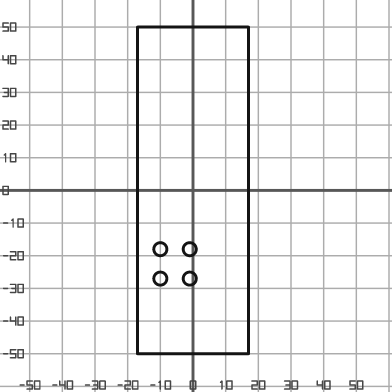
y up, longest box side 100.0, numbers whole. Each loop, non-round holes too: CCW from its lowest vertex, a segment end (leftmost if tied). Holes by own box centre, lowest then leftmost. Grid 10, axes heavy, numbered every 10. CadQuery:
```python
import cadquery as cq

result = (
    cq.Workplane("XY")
    .moveTo(-17.0, -50.0)
    .lineTo(17.0, -50.0)
    .lineTo(17.0, 50.0)
    .lineTo(-17.0, 50.0)
    .close()
    .moveTo(-10.0, -27.0)
    .circle(2.0)
    .moveTo(-1.0, -27.0)
    .circle(2.0)
    .moveTo(-10.0, -18.0)
    .circle(2.0)
    .moveTo(-1.0, -18.0)
    .circle(2.0)
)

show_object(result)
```